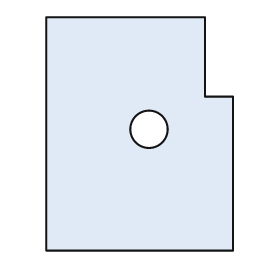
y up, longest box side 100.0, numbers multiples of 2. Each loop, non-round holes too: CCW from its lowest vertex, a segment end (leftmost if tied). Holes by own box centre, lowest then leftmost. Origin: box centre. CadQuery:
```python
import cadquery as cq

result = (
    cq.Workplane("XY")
    .moveTo(-40.0, -50.0)
    .lineTo(40.0, -50.0)
    .lineTo(40.0, 16.0)
    .lineTo(28.0, 16.0)
    .lineTo(28.0, 50.0)
    .lineTo(-40.0, 50.0)
    .close()
    .moveTo(4.0, 2.0)
    .circle(8.0)
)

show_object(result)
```